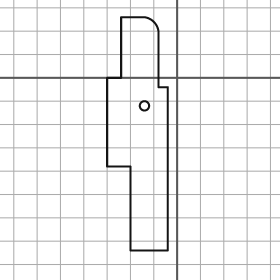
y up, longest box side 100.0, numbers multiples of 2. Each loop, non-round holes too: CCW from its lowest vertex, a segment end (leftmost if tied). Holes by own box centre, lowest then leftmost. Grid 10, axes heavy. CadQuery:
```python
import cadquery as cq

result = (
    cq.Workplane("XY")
    .moveTo(-20.0, -74.0)
    .lineTo(-4.0, -74.0)
    .lineTo(-4.0, -4.0)
    .lineTo(-8.0, -4.0)
    .lineTo(-8.0, 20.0)
    .threePointArc((-10.0, 24.0), (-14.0, 26.0))
    .lineTo(-24.0, 26.0)
    .lineTo(-24.0, 0.0)
    .lineTo(-30.0, 0.0)
    .lineTo(-30.0, -38.0)
    .lineTo(-20.0, -38.0)
    .close()
    .moveTo(-14.0, -12.0)
    .circle(2.0)
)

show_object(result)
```